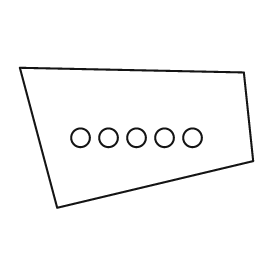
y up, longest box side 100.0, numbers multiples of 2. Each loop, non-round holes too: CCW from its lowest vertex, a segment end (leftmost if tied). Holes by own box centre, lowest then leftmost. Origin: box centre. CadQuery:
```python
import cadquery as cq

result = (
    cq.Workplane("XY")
    .moveTo(-34.0, -30.0)
    .lineTo(50.0, -10.0)
    .lineTo(46.0, 28.0)
    .lineTo(-50.0, 30.0)
    .close()
    .moveTo(-24.0, 0.0)
    .circle(4.0)
    .moveTo(-12.0, 0.0)
    .circle(4.0)
    .moveTo(0.0, 0.0)
    .circle(4.0)
    .moveTo(12.0, 0.0)
    .circle(4.0)
    .moveTo(24.0, 0.0)
    .circle(4.0)
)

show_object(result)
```